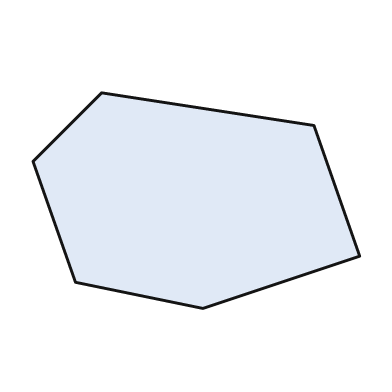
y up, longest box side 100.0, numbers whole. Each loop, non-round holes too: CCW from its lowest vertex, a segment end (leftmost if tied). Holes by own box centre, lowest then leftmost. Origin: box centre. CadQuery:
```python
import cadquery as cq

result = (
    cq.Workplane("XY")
    .moveTo(2.0, -33.0)
    .lineTo(50.0, -17.0)
    .lineTo(36.0, 23.0)
    .lineTo(-29.0, 33.0)
    .lineTo(-50.0, 12.0)
    .lineTo(-37.0, -25.0)
    .close()
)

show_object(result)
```